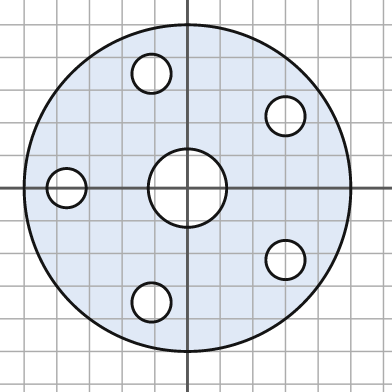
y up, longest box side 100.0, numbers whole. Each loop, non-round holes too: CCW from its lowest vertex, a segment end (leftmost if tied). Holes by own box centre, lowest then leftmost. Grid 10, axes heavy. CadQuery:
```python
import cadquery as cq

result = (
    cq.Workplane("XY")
    .moveTo(0.0, 0.0)
    .circle(50.0)
    .moveTo(-11.0, -35.0)
    .circle(6.0)
    .moveTo(30.0, -22.0)
    .circle(6.0)
    .moveTo(-37.0, 0.0)
    .circle(6.0)
    .moveTo(0.0, 0.0)
    .circle(12.0)
    .moveTo(30.0, 22.0)
    .circle(6.0)
    .moveTo(-11.0, 35.0)
    .circle(6.0)
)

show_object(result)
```